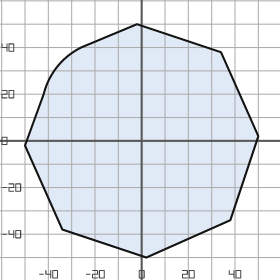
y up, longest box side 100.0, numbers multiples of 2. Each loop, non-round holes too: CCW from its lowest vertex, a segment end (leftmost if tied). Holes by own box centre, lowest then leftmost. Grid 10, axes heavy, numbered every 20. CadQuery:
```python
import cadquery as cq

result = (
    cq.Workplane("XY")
    .moveTo(2.0, -50.0)
    .lineTo(38.0, -34.0)
    .lineTo(50.0, 2.0)
    .lineTo(34.0, 38.0)
    .lineTo(-2.0, 50.0)
    .lineTo(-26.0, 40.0)
    .threePointArc((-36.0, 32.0), (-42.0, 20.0))
    .lineTo(-50.0, -2.0)
    .lineTo(-34.0, -38.0)
    .close()
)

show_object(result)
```